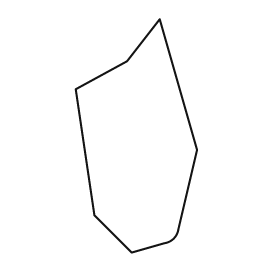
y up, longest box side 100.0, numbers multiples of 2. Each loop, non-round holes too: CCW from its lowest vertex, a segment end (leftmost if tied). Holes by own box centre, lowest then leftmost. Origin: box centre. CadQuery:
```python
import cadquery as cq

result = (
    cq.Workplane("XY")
    .moveTo(-2.0, -50.0)
    .lineTo(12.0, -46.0)
    .threePointArc((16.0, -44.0), (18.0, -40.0))
    .lineTo(26.0, -6.0)
    .lineTo(10.0, 50.0)
    .lineTo(-4.0, 32.0)
    .lineTo(-26.0, 20.0)
    .lineTo(-18.0, -34.0)
    .close()
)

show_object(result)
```